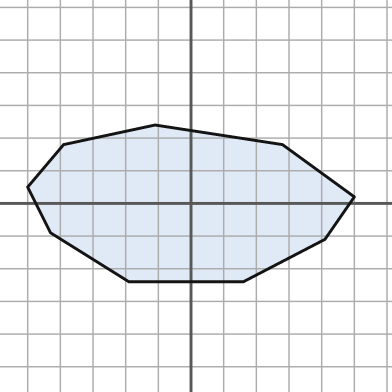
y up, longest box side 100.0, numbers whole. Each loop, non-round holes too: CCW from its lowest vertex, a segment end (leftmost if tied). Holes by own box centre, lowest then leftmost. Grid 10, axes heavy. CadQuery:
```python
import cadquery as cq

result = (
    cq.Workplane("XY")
    .moveTo(-19.0, -24.0)
    .lineTo(16.0, -24.0)
    .lineTo(41.0, -11.0)
    .lineTo(50.0, 2.0)
    .lineTo(28.0, 18.0)
    .lineTo(-11.0, 24.0)
    .lineTo(-39.0, 18.0)
    .lineTo(-50.0, 5.0)
    .lineTo(-43.0, -9.0)
    .close()
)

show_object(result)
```